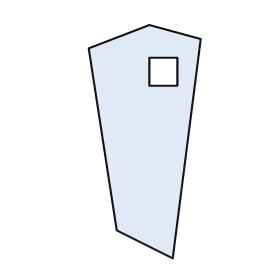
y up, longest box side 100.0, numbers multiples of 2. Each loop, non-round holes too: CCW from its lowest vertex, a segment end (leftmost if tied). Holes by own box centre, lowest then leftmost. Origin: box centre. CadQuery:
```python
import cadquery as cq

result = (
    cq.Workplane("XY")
    .moveTo(12.0, -50.0)
    .lineTo(24.0, 44.0)
    .lineTo(2.0, 50.0)
    .lineTo(-24.0, 40.0)
    .lineTo(-12.0, -38.0)
    .close()
    .moveTo(2.0, 24.0)
    .lineTo(14.0, 24.0)
    .lineTo(14.0, 36.0)
    .lineTo(2.0, 36.0)
    .close()
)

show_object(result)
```